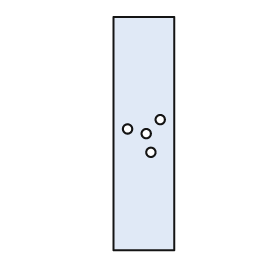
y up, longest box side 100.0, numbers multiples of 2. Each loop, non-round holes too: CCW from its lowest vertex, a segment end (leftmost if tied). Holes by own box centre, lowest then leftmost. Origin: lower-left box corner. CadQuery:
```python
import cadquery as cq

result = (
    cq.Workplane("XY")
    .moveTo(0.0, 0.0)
    .lineTo(26.0, 0.0)
    .lineTo(26.0, 100.0)
    .lineTo(0.0, 100.0)
    .close()
    .moveTo(16.0, 42.0)
    .circle(2.0)
    .moveTo(14.0, 50.0)
    .circle(2.0)
    .moveTo(6.0, 52.0)
    .circle(2.0)
    .moveTo(20.0, 56.0)
    .circle(2.0)
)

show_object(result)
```